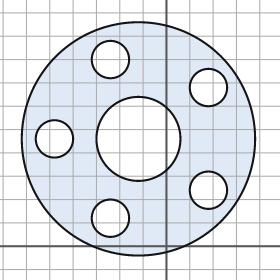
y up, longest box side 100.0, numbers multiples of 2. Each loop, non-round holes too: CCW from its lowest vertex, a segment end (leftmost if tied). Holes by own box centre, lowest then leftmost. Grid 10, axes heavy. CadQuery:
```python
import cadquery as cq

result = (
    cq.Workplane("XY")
    .moveTo(-12.0, 46.0)
    .circle(50.0)
    .moveTo(-24.0, 12.0)
    .circle(8.0)
    .moveTo(18.0, 24.0)
    .circle(8.0)
    .moveTo(-48.0, 46.0)
    .circle(8.0)
    .moveTo(-12.0, 46.0)
    .circle(18.0)
    .moveTo(18.0, 68.0)
    .circle(8.0)
    .moveTo(-24.0, 80.0)
    .circle(8.0)
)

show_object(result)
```